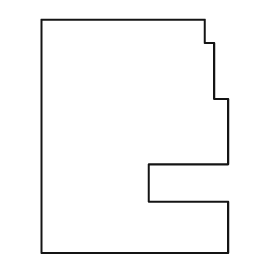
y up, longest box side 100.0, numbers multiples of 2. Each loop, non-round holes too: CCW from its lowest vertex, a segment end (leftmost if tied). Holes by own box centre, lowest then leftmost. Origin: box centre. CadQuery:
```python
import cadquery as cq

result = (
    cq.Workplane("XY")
    .moveTo(-40.0, -50.0)
    .lineTo(40.0, -50.0)
    .lineTo(40.0, -28.0)
    .lineTo(6.0, -28.0)
    .lineTo(6.0, -12.0)
    .lineTo(40.0, -12.0)
    .lineTo(40.0, 16.0)
    .lineTo(34.0, 16.0)
    .lineTo(34.0, 40.0)
    .lineTo(30.0, 40.0)
    .lineTo(30.0, 50.0)
    .lineTo(-40.0, 50.0)
    .close()
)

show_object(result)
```